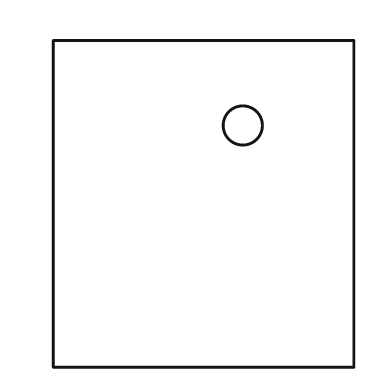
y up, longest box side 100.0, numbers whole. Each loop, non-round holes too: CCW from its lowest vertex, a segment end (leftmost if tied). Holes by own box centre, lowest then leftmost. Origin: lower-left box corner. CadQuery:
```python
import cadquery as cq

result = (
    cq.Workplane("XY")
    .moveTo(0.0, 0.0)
    .lineTo(92.0, 0.0)
    .lineTo(92.0, 100.0)
    .lineTo(0.0, 100.0)
    .close()
    .moveTo(58.0, 74.0)
    .circle(6.0)
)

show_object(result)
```